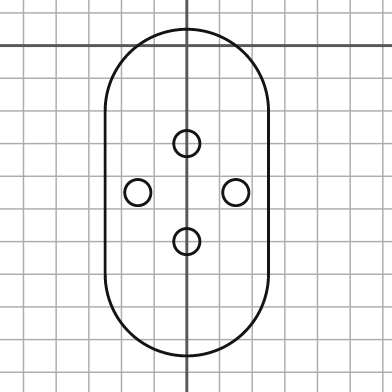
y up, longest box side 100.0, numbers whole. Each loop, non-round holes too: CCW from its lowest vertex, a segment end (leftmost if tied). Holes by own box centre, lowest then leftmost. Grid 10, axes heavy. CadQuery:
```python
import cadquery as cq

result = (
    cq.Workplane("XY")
    .moveTo(-25.0, -70.0)
    .threePointArc((0.0, -95.0), (25.0, -70.0))
    .lineTo(25.0, -20.0)
    .threePointArc((0.0, 5.0), (-25.0, -20.0))
    .close()
    .moveTo(0.0, -60.0)
    .circle(4.0)
    .moveTo(-15.0, -45.0)
    .circle(4.0)
    .moveTo(15.0, -45.0)
    .circle(4.0)
    .moveTo(0.0, -30.0)
    .circle(4.0)
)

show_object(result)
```